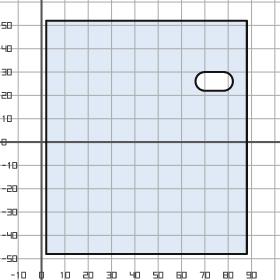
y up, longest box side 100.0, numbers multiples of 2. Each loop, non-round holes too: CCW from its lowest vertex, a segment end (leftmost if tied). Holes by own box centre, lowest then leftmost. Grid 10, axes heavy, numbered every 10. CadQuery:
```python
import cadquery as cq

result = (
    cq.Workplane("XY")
    .moveTo(2.0, -48.0)
    .lineTo(88.0, -48.0)
    .lineTo(88.0, 52.0)
    .lineTo(2.0, 52.0)
    .close()
    .moveTo(70.0, 22.0)
    .lineTo(78.0, 22.0)
    .threePointArc((82.0, 26.0), (78.0, 30.0))
    .lineTo(70.0, 30.0)
    .threePointArc((66.0, 26.0), (70.0, 22.0))
    .close()
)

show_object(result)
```